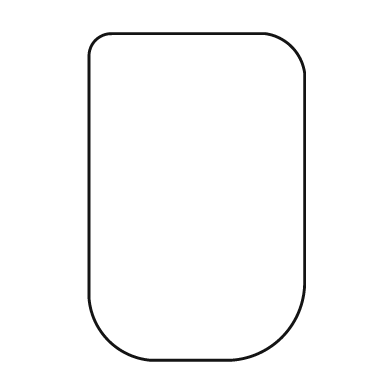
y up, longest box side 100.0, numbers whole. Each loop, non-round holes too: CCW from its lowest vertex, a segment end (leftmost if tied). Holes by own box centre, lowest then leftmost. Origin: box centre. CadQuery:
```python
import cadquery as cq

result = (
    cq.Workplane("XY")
    .moveTo(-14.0, -50.0)
    .lineTo(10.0, -50.0)
    .threePointArc((26.0, -43.0), (33.0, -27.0))
    .lineTo(33.0, 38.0)
    .threePointArc((29.0, 46.0), (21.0, 50.0))
    .lineTo(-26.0, 50.0)
    .threePointArc((-31.0, 48.0), (-33.0, 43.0))
    .lineTo(-33.0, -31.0)
    .threePointArc((-27.0, -44.0), (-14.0, -50.0))
    .close()
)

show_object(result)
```